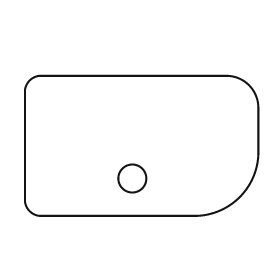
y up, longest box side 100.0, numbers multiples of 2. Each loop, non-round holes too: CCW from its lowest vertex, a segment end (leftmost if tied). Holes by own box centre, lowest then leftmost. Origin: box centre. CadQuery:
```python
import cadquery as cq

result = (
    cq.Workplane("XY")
    .moveTo(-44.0, -30.0)
    .lineTo(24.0, -30.0)
    .threePointArc((42.0, -22.0), (50.0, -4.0))
    .lineTo(50.0, 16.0)
    .threePointArc((46.0, 26.0), (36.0, 30.0))
    .lineTo(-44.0, 30.0)
    .threePointArc((-48.0, 28.0), (-50.0, 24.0))
    .lineTo(-50.0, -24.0)
    .threePointArc((-48.0, -28.0), (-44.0, -30.0))
    .close()
    .moveTo(-4.0, -14.0)
    .circle(6.0)
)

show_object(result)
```